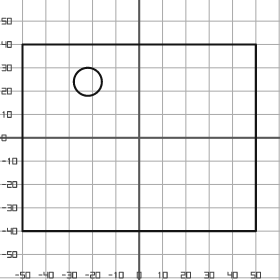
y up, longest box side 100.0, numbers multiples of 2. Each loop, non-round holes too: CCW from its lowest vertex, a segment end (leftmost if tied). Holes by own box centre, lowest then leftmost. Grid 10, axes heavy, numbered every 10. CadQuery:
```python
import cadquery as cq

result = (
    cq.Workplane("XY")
    .moveTo(-50.0, -40.0)
    .lineTo(50.0, -40.0)
    .lineTo(50.0, 40.0)
    .lineTo(-50.0, 40.0)
    .close()
    .moveTo(-22.0, 24.0)
    .circle(6.0)
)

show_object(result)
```